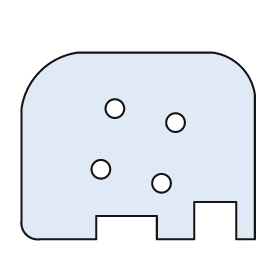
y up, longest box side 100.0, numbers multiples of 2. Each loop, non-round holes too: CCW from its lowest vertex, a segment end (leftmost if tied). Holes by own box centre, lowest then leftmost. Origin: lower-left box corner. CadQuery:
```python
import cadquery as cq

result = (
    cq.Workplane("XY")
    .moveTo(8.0, 0.0)
    .lineTo(32.0, 0.0)
    .lineTo(32.0, 10.0)
    .lineTo(58.0, 10.0)
    .lineTo(58.0, 0.0)
    .lineTo(74.0, 0.0)
    .lineTo(74.0, 16.0)
    .lineTo(92.0, 16.0)
    .lineTo(92.0, 0.0)
    .lineTo(100.0, 0.0)
    .lineTo(100.0, 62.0)
    .threePointArc((94.0, 74.0), (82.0, 80.0))
    .lineTo(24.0, 80.0)
    .threePointArc((8.0, 72.0), (0.0, 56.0))
    .lineTo(0.0, 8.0)
    .threePointArc((2.0, 2.0), (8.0, 0.0))
    .close()
    .moveTo(60.0, 24.0)
    .circle(4.0)
    .moveTo(34.0, 30.0)
    .circle(4.0)
    .moveTo(66.0, 50.0)
    .circle(4.0)
    .moveTo(40.0, 56.0)
    .circle(4.0)
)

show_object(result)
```